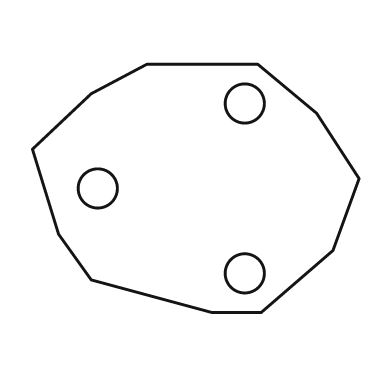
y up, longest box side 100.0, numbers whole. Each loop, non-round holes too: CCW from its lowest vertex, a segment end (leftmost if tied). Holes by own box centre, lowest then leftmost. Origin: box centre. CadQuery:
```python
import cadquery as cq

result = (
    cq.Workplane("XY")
    .moveTo(5.0, -38.0)
    .lineTo(20.0, -38.0)
    .lineTo(42.0, -19.0)
    .lineTo(50.0, 3.0)
    .lineTo(37.0, 23.0)
    .lineTo(19.0, 38.0)
    .lineTo(-15.0, 38.0)
    .lineTo(-32.0, 29.0)
    .lineTo(-50.0, 12.0)
    .lineTo(-42.0, -14.0)
    .lineTo(-32.0, -28.0)
    .close()
    .moveTo(15.0, -26.0)
    .circle(6.0)
    .moveTo(-30.0, 0.0)
    .circle(6.0)
    .moveTo(15.0, 26.0)
    .circle(6.0)
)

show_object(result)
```